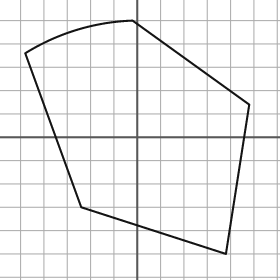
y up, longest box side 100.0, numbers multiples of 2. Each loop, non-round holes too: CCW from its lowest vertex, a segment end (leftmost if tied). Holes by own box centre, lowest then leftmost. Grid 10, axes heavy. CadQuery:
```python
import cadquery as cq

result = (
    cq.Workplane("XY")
    .moveTo(38.0, -50.0)
    .lineTo(48.0, 14.0)
    .lineTo(-2.0, 50.0)
    .threePointArc((-26.0, 46.0), (-48.0, 36.0))
    .lineTo(-24.0, -30.0)
    .close()
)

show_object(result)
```